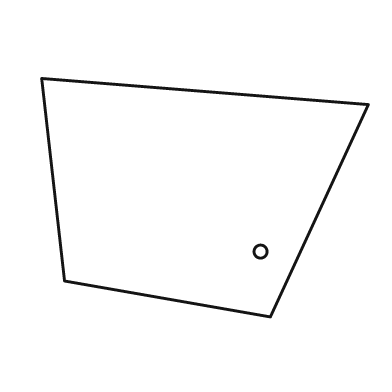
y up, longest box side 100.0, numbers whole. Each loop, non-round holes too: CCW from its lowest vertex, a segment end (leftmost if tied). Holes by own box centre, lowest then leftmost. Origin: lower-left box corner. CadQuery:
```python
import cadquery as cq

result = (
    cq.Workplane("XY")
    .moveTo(70.0, 0.0)
    .lineTo(100.0, 65.0)
    .lineTo(0.0, 73.0)
    .lineTo(7.0, 11.0)
    .close()
    .moveTo(67.0, 20.0)
    .circle(2.0)
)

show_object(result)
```